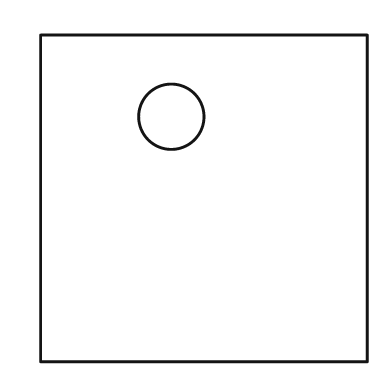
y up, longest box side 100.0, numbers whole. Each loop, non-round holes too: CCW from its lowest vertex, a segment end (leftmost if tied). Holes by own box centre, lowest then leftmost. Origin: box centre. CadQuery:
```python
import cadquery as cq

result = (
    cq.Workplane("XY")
    .moveTo(-50.0, -50.0)
    .lineTo(50.0, -50.0)
    .lineTo(50.0, 50.0)
    .lineTo(-50.0, 50.0)
    .close()
    .moveTo(-10.0, 25.0)
    .circle(10.0)
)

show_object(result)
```